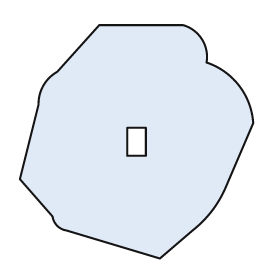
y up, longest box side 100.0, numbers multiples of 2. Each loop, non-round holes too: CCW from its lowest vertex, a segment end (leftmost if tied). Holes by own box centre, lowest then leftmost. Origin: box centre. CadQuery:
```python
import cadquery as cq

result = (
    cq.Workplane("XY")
    .moveTo(10.0, -50.0)
    .lineTo(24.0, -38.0)
    .threePointArc((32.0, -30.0), (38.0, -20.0))
    .lineTo(50.0, 8.0)
    .threePointArc((44.0, 24.0), (30.0, 34.0))
    .threePointArc((28.0, 44.0), (20.0, 50.0))
    .lineTo(-16.0, 50.0)
    .lineTo(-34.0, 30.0)
    .threePointArc((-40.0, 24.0), (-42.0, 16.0))
    .lineTo(-50.0, -16.0)
    .lineTo(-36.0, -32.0)
    .threePointArc((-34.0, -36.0), (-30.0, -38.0))
    .close()
    .moveTo(-4.0, -6.0)
    .lineTo(4.0, -6.0)
    .lineTo(4.0, 6.0)
    .lineTo(-4.0, 6.0)
    .close()
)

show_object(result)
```